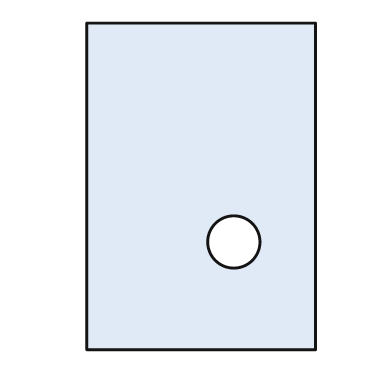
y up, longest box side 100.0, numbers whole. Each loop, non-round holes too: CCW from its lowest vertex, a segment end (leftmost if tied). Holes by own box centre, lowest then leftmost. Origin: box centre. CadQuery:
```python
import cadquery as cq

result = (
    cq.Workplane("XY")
    .moveTo(-35.0, -50.0)
    .lineTo(35.0, -50.0)
    .lineTo(35.0, 50.0)
    .lineTo(-35.0, 50.0)
    .close()
    .moveTo(10.0, -17.0)
    .circle(8.0)
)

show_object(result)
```